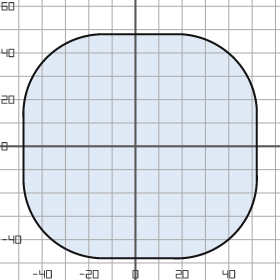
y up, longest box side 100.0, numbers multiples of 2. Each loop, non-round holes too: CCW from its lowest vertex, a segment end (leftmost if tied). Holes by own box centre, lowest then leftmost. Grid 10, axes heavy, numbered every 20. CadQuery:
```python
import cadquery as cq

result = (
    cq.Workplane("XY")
    .moveTo(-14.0, -48.0)
    .lineTo(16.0, -48.0)
    .threePointArc((42.0, -38.0), (52.0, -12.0))
    .lineTo(52.0, 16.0)
    .threePointArc((42.0, 38.0), (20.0, 48.0))
    .lineTo(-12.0, 48.0)
    .threePointArc((-38.0, 38.0), (-48.0, 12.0))
    .lineTo(-48.0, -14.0)
    .threePointArc((-38.0, -38.0), (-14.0, -48.0))
    .close()
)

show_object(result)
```